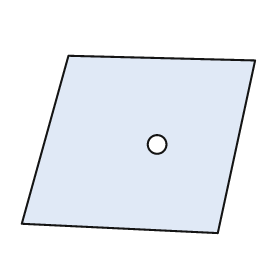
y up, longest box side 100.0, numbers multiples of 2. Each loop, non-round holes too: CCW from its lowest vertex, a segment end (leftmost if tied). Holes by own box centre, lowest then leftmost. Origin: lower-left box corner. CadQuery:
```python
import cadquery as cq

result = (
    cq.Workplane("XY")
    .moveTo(84.0, 0.0)
    .lineTo(100.0, 74.0)
    .lineTo(20.0, 76.0)
    .lineTo(0.0, 4.0)
    .close()
    .moveTo(58.0, 38.0)
    .circle(4.0)
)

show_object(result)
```